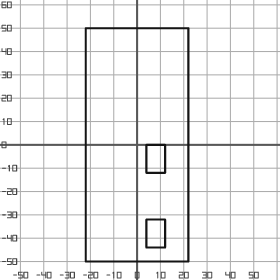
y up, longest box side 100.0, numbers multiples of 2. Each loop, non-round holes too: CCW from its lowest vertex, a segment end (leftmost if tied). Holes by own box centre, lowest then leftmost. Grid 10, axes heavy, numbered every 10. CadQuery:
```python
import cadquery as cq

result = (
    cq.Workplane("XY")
    .moveTo(-22.0, -50.0)
    .lineTo(22.0, -50.0)
    .lineTo(22.0, 50.0)
    .lineTo(-22.0, 50.0)
    .close()
    .moveTo(4.0, -44.0)
    .lineTo(12.0, -44.0)
    .lineTo(12.0, -32.0)
    .lineTo(4.0, -32.0)
    .close()
    .moveTo(4.0, -12.0)
    .lineTo(12.0, -12.0)
    .lineTo(12.0, 0.0)
    .lineTo(4.0, 0.0)
    .close()
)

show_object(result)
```